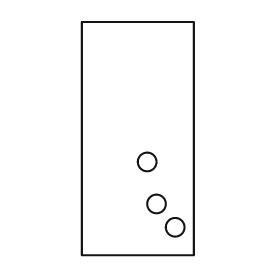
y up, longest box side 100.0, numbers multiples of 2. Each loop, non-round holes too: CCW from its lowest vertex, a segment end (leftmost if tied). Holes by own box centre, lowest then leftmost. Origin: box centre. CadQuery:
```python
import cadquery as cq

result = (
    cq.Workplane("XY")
    .moveTo(-24.0, -50.0)
    .lineTo(24.0, -50.0)
    .lineTo(24.0, 50.0)
    .lineTo(-24.0, 50.0)
    .close()
    .moveTo(16.0, -38.0)
    .circle(4.0)
    .moveTo(8.0, -28.0)
    .circle(4.0)
    .moveTo(4.0, -10.0)
    .circle(4.0)
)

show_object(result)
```